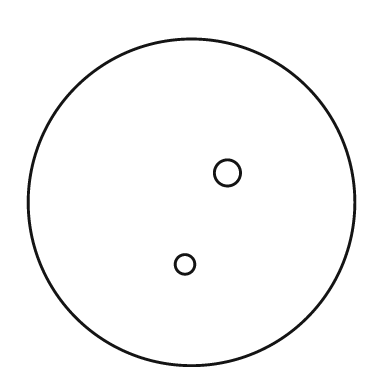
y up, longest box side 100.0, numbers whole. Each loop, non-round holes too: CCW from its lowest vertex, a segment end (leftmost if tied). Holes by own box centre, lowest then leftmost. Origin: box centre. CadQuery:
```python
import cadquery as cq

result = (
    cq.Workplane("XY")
    .moveTo(0.0, 0.0)
    .circle(50.0)
    .moveTo(-2.0, -19.0)
    .circle(3.0)
    .moveTo(11.0, 9.0)
    .circle(4.0)
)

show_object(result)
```